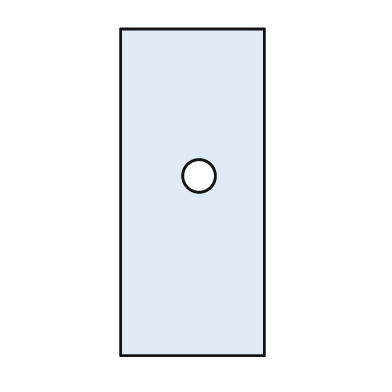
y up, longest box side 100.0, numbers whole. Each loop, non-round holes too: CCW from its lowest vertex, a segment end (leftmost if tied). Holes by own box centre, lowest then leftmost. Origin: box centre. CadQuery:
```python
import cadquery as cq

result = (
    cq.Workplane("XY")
    .moveTo(-22.0, -50.0)
    .lineTo(22.0, -50.0)
    .lineTo(22.0, 50.0)
    .lineTo(-22.0, 50.0)
    .close()
    .moveTo(2.0, 5.0)
    .circle(5.0)
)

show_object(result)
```